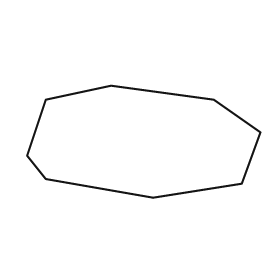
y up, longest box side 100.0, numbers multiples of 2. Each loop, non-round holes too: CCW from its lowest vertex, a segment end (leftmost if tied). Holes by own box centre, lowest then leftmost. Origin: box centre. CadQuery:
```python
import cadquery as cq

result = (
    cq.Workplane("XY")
    .moveTo(4.0, -24.0)
    .lineTo(42.0, -18.0)
    .lineTo(50.0, 4.0)
    .lineTo(30.0, 18.0)
    .lineTo(-14.0, 24.0)
    .lineTo(-42.0, 18.0)
    .lineTo(-50.0, -6.0)
    .lineTo(-42.0, -16.0)
    .close()
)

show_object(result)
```